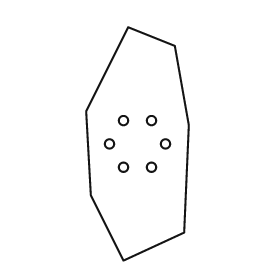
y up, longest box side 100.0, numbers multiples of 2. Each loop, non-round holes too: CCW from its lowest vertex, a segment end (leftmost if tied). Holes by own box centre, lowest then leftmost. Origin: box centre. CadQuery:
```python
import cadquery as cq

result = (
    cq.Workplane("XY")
    .moveTo(-6.0, -50.0)
    .lineTo(20.0, -38.0)
    .lineTo(22.0, 8.0)
    .lineTo(16.0, 42.0)
    .lineTo(-4.0, 50.0)
    .lineTo(-22.0, 14.0)
    .lineTo(-20.0, -22.0)
    .close()
    .moveTo(-6.0, -10.0)
    .circle(2.0)
    .moveTo(6.0, -10.0)
    .circle(2.0)
    .moveTo(-12.0, 0.0)
    .circle(2.0)
    .moveTo(12.0, 0.0)
    .circle(2.0)
    .moveTo(-6.0, 10.0)
    .circle(2.0)
    .moveTo(6.0, 10.0)
    .circle(2.0)
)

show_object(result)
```